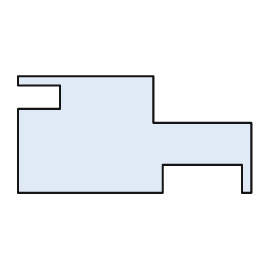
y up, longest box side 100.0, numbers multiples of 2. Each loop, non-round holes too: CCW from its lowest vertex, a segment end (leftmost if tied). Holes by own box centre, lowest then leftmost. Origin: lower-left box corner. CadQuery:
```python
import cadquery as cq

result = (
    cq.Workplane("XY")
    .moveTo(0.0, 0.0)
    .lineTo(62.0, 0.0)
    .lineTo(62.0, 12.0)
    .lineTo(96.0, 12.0)
    .lineTo(96.0, 0.0)
    .lineTo(100.0, 0.0)
    .lineTo(100.0, 30.0)
    .lineTo(58.0, 30.0)
    .lineTo(58.0, 50.0)
    .lineTo(0.0, 50.0)
    .lineTo(0.0, 46.0)
    .lineTo(18.0, 46.0)
    .lineTo(18.0, 36.0)
    .lineTo(0.0, 36.0)
    .close()
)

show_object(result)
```